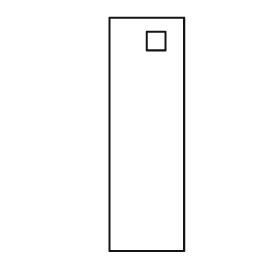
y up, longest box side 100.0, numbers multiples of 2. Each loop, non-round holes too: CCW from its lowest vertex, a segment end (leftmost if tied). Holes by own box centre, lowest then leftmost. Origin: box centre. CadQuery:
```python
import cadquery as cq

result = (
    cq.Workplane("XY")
    .moveTo(-16.0, -50.0)
    .lineTo(16.0, -50.0)
    .lineTo(16.0, 50.0)
    .lineTo(-16.0, 50.0)
    .close()
    .moveTo(0.0, 36.0)
    .lineTo(8.0, 36.0)
    .lineTo(8.0, 44.0)
    .lineTo(0.0, 44.0)
    .close()
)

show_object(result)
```